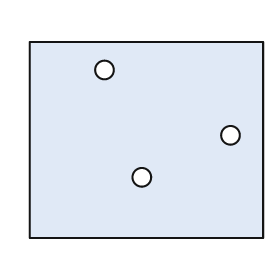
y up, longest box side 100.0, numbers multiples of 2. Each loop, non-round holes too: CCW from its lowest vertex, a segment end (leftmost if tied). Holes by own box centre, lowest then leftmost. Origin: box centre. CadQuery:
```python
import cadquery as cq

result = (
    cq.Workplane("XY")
    .moveTo(-50.0, -42.0)
    .lineTo(50.0, -42.0)
    .lineTo(50.0, 42.0)
    .lineTo(-50.0, 42.0)
    .close()
    .moveTo(-2.0, -16.0)
    .circle(4.0)
    .moveTo(36.0, 2.0)
    .circle(4.0)
    .moveTo(-18.0, 30.0)
    .circle(4.0)
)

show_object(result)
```